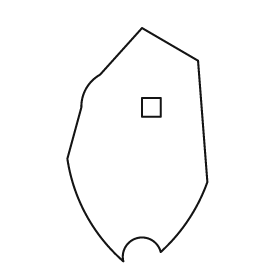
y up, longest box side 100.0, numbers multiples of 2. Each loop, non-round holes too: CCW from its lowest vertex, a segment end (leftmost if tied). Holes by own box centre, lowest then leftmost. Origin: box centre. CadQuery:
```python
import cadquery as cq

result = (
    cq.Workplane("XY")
    .moveTo(-6.0, -50.0)
    .threePointArc((0.0, -40.0), (10.0, -46.0))
    .threePointArc((22.0, -32.0), (30.0, -16.0))
    .lineTo(26.0, 36.0)
    .lineTo(2.0, 50.0)
    .lineTo(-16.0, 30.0)
    .threePointArc((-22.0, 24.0), (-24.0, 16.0))
    .lineTo(-30.0, -6.0)
    .threePointArc((-22.0, -30.0), (-6.0, -50.0))
    .close()
    .moveTo(2.0, 12.0)
    .lineTo(10.0, 12.0)
    .lineTo(10.0, 20.0)
    .lineTo(2.0, 20.0)
    .close()
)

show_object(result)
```